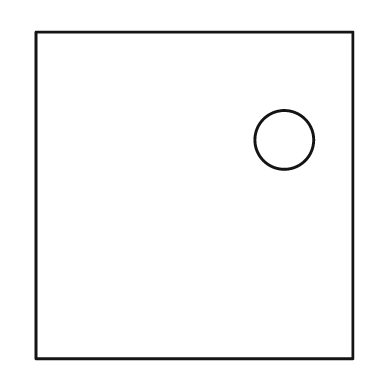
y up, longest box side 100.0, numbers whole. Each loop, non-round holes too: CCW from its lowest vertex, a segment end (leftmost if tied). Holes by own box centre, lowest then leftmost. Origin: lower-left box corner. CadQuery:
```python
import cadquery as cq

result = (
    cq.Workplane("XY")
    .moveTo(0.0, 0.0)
    .lineTo(97.0, 0.0)
    .lineTo(97.0, 100.0)
    .lineTo(0.0, 100.0)
    .close()
    .moveTo(76.0, 67.0)
    .circle(9.0)
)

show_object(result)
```